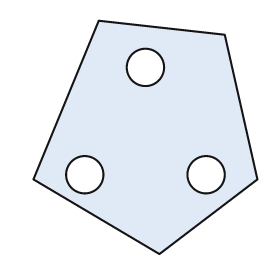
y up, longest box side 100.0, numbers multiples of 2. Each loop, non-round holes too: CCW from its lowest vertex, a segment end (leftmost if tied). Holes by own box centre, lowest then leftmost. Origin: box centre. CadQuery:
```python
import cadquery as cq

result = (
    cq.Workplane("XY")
    .moveTo(6.0, -50.0)
    .lineTo(48.0, -18.0)
    .lineTo(34.0, 44.0)
    .lineTo(-20.0, 50.0)
    .lineTo(-48.0, -18.0)
    .close()
    .moveTo(-26.0, -16.0)
    .circle(8.0)
    .moveTo(26.0, -16.0)
    .circle(8.0)
    .moveTo(0.0, 30.0)
    .circle(8.0)
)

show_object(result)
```